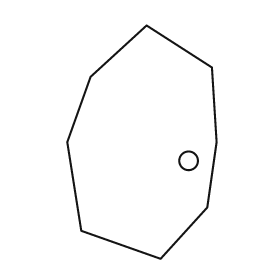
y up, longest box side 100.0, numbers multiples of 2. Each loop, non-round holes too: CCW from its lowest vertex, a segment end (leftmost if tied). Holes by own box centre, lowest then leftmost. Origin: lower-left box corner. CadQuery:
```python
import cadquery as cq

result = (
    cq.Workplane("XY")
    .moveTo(40.0, 0.0)
    .lineTo(60.0, 22.0)
    .lineTo(64.0, 50.0)
    .lineTo(62.0, 82.0)
    .lineTo(34.0, 100.0)
    .lineTo(10.0, 78.0)
    .lineTo(0.0, 50.0)
    .lineTo(6.0, 12.0)
    .close()
    .moveTo(52.0, 42.0)
    .circle(4.0)
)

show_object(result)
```